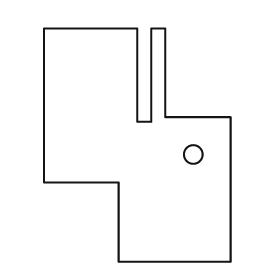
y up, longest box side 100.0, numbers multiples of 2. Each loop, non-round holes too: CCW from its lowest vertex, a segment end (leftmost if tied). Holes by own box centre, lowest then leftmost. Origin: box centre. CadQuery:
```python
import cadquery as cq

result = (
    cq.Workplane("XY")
    .moveTo(-8.0, -50.0)
    .lineTo(40.0, -50.0)
    .lineTo(40.0, 12.0)
    .lineTo(12.0, 12.0)
    .lineTo(12.0, 50.0)
    .lineTo(6.0, 50.0)
    .lineTo(6.0, 10.0)
    .lineTo(0.0, 10.0)
    .lineTo(0.0, 50.0)
    .lineTo(-40.0, 50.0)
    .lineTo(-40.0, -16.0)
    .lineTo(-8.0, -16.0)
    .close()
    .moveTo(24.0, -4.0)
    .circle(4.0)
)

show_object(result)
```